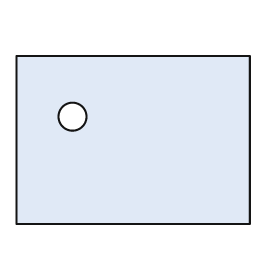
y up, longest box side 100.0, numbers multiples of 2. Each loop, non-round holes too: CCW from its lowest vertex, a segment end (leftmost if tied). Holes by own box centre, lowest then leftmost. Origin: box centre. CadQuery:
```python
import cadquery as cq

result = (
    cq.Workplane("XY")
    .moveTo(-50.0, -36.0)
    .lineTo(50.0, -36.0)
    .lineTo(50.0, 36.0)
    .lineTo(-50.0, 36.0)
    .close()
    .moveTo(-26.0, 10.0)
    .circle(6.0)
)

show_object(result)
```